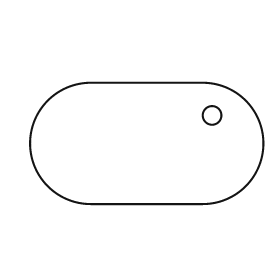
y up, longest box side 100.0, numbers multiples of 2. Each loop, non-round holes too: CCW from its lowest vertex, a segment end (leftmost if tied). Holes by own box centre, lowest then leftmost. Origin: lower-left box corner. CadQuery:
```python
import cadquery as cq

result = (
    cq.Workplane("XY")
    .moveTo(26.0, 0.0)
    .lineTo(74.0, 0.0)
    .threePointArc((100.0, 26.0), (74.0, 52.0))
    .lineTo(26.0, 52.0)
    .threePointArc((0.0, 26.0), (26.0, 0.0))
    .close()
    .moveTo(78.0, 38.0)
    .circle(4.0)
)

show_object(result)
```